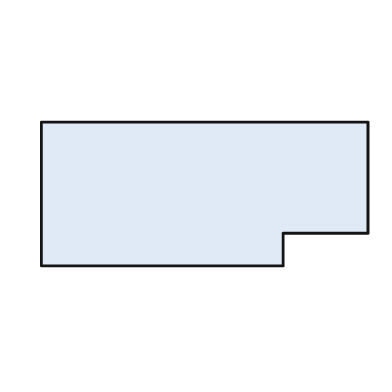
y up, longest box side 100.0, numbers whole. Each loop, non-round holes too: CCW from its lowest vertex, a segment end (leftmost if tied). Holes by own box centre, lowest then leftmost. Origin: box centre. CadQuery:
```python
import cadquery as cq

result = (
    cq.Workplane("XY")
    .moveTo(-50.0, -22.0)
    .lineTo(24.0, -22.0)
    .lineTo(24.0, -12.0)
    .lineTo(50.0, -12.0)
    .lineTo(50.0, 22.0)
    .lineTo(-50.0, 22.0)
    .close()
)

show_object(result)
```